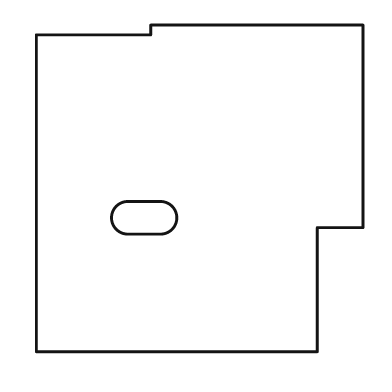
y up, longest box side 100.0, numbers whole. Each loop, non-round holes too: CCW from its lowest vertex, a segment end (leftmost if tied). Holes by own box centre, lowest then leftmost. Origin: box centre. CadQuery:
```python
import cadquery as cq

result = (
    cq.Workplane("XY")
    .moveTo(-50.0, -50.0)
    .lineTo(36.0, -50.0)
    .lineTo(36.0, -12.0)
    .lineTo(50.0, -12.0)
    .lineTo(50.0, 50.0)
    .lineTo(-15.0, 50.0)
    .lineTo(-15.0, 47.0)
    .lineTo(-50.0, 47.0)
    .close()
    .moveTo(-22.0, -14.0)
    .lineTo(-12.0, -14.0)
    .threePointArc((-7.0, -9.0), (-12.0, -4.0))
    .lineTo(-22.0, -4.0)
    .threePointArc((-27.0, -9.0), (-22.0, -14.0))
    .close()
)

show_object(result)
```